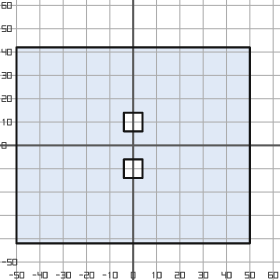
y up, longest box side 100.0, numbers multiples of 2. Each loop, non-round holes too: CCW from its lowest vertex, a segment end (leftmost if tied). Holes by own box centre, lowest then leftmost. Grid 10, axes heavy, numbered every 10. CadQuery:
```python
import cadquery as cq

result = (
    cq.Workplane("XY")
    .moveTo(-50.0, -42.0)
    .lineTo(50.0, -42.0)
    .lineTo(50.0, 42.0)
    .lineTo(-50.0, 42.0)
    .close()
    .moveTo(-4.0, -14.0)
    .lineTo(4.0, -14.0)
    .lineTo(4.0, -6.0)
    .lineTo(-4.0, -6.0)
    .close()
    .moveTo(-4.0, 6.0)
    .lineTo(4.0, 6.0)
    .lineTo(4.0, 14.0)
    .lineTo(-4.0, 14.0)
    .close()
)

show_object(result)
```